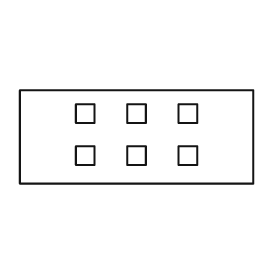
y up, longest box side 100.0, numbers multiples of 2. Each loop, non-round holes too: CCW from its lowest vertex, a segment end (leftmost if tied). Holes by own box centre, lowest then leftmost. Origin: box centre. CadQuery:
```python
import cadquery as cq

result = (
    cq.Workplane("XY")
    .moveTo(-50.0, -20.0)
    .lineTo(50.0, -20.0)
    .lineTo(50.0, 20.0)
    .lineTo(-50.0, 20.0)
    .close()
    .moveTo(-26.0, -12.0)
    .lineTo(-18.0, -12.0)
    .lineTo(-18.0, -4.0)
    .lineTo(-26.0, -4.0)
    .close()
    .moveTo(-4.0, -12.0)
    .lineTo(4.0, -12.0)
    .lineTo(4.0, -4.0)
    .lineTo(-4.0, -4.0)
    .close()
    .moveTo(18.0, -12.0)
    .lineTo(26.0, -12.0)
    .lineTo(26.0, -4.0)
    .lineTo(18.0, -4.0)
    .close()
    .moveTo(-26.0, 6.0)
    .lineTo(-18.0, 6.0)
    .lineTo(-18.0, 14.0)
    .lineTo(-26.0, 14.0)
    .close()
    .moveTo(-4.0, 6.0)
    .lineTo(4.0, 6.0)
    .lineTo(4.0, 14.0)
    .lineTo(-4.0, 14.0)
    .close()
    .moveTo(18.0, 6.0)
    .lineTo(26.0, 6.0)
    .lineTo(26.0, 14.0)
    .lineTo(18.0, 14.0)
    .close()
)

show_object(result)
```